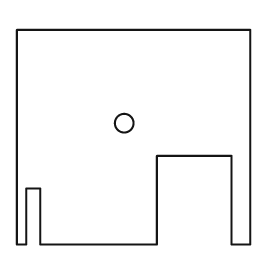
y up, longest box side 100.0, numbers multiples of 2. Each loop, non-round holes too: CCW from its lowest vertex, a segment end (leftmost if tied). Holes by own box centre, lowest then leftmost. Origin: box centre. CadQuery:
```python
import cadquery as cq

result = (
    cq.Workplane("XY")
    .moveTo(-50.0, -46.0)
    .lineTo(-46.0, -46.0)
    .lineTo(-46.0, -22.0)
    .lineTo(-40.0, -22.0)
    .lineTo(-40.0, -46.0)
    .lineTo(10.0, -46.0)
    .lineTo(10.0, -8.0)
    .lineTo(42.0, -8.0)
    .lineTo(42.0, -46.0)
    .lineTo(50.0, -46.0)
    .lineTo(50.0, 46.0)
    .lineTo(-50.0, 46.0)
    .close()
    .moveTo(-4.0, 6.0)
    .circle(4.0)
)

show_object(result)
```